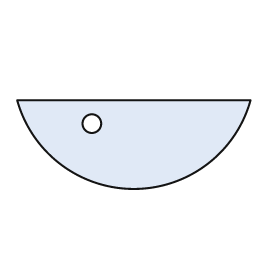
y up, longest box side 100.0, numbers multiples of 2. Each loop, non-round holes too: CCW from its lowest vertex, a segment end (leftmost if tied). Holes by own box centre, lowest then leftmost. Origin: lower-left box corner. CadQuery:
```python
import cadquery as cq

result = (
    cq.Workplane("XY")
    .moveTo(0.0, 38.0)
    .threePointArc((50.0, 0.0), (100.0, 38.0))
    .close()
    .moveTo(32.0, 28.0)
    .circle(4.0)
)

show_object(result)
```